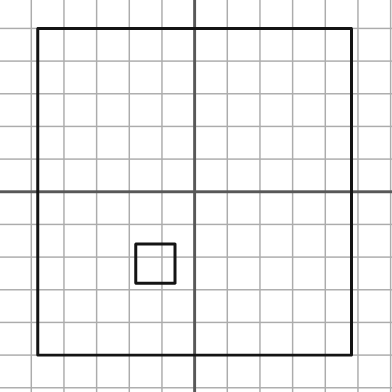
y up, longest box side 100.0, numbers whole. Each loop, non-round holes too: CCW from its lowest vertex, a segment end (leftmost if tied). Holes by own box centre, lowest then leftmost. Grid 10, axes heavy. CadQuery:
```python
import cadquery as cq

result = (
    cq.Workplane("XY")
    .moveTo(-48.0, -50.0)
    .lineTo(48.0, -50.0)
    .lineTo(48.0, 50.0)
    .lineTo(-48.0, 50.0)
    .close()
    .moveTo(-18.0, -28.0)
    .lineTo(-6.0, -28.0)
    .lineTo(-6.0, -16.0)
    .lineTo(-18.0, -16.0)
    .close()
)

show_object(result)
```